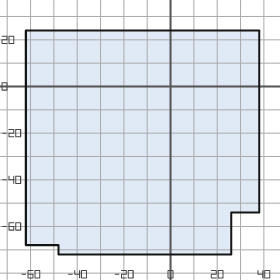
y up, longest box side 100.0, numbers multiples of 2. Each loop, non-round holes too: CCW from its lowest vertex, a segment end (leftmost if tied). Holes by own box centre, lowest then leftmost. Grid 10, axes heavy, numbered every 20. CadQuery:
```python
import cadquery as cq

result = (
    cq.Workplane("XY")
    .moveTo(-48.0, -72.0)
    .lineTo(26.0, -72.0)
    .lineTo(26.0, -54.0)
    .lineTo(38.0, -54.0)
    .lineTo(38.0, 24.0)
    .lineTo(-62.0, 24.0)
    .lineTo(-62.0, -68.0)
    .lineTo(-48.0, -68.0)
    .close()
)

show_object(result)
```